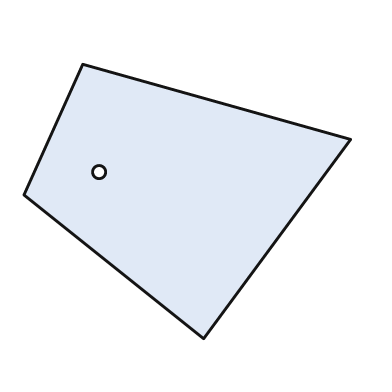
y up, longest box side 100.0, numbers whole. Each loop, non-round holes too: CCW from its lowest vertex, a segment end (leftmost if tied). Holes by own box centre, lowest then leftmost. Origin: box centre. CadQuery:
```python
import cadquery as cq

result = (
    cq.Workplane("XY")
    .moveTo(5.0, -42.0)
    .lineTo(50.0, 19.0)
    .lineTo(-32.0, 42.0)
    .lineTo(-50.0, 2.0)
    .close()
    .moveTo(-27.0, 9.0)
    .circle(2.0)
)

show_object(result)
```